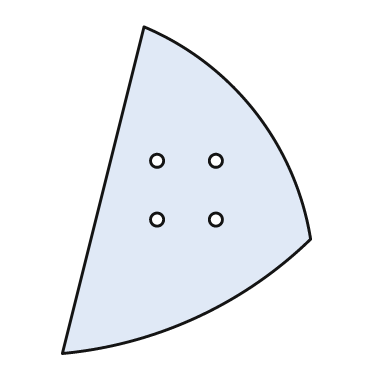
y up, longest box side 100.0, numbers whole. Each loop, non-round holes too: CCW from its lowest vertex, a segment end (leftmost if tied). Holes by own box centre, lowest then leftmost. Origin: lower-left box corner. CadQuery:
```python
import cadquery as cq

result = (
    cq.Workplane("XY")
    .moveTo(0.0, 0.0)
    .threePointArc((41.0, 11.0), (76.0, 35.0))
    .threePointArc((59.0, 74.0), (25.0, 100.0))
    .close()
    .moveTo(29.0, 41.0)
    .circle(2.0)
    .moveTo(47.0, 41.0)
    .circle(2.0)
    .moveTo(29.0, 59.0)
    .circle(2.0)
    .moveTo(47.0, 59.0)
    .circle(2.0)
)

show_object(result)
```